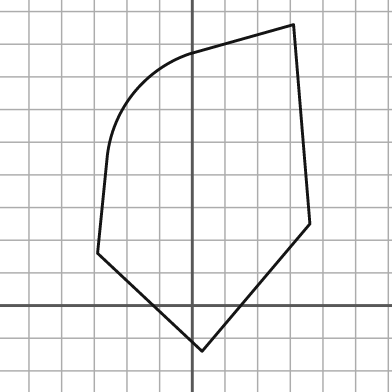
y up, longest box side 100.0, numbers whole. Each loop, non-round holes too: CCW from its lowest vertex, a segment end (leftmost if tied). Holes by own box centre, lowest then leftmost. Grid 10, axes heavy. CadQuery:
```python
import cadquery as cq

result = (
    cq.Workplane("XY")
    .moveTo(3.0, -14.0)
    .lineTo(36.0, 25.0)
    .lineTo(31.0, 86.0)
    .lineTo(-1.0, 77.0)
    .threePointArc((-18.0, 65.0), (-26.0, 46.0))
    .lineTo(-29.0, 16.0)
    .close()
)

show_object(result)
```